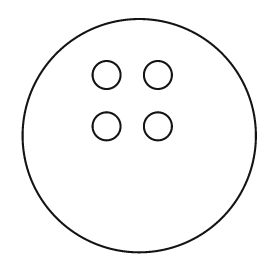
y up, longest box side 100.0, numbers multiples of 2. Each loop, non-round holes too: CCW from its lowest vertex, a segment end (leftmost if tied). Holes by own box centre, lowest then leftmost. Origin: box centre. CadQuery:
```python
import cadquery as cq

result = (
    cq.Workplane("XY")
    .moveTo(0.0, 0.0)
    .circle(50.0)
    .moveTo(-14.0, 4.0)
    .circle(6.0)
    .moveTo(8.0, 4.0)
    .circle(6.0)
    .moveTo(-14.0, 26.0)
    .circle(6.0)
    .moveTo(8.0, 26.0)
    .circle(6.0)
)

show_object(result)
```